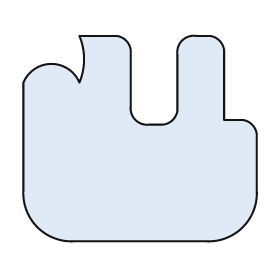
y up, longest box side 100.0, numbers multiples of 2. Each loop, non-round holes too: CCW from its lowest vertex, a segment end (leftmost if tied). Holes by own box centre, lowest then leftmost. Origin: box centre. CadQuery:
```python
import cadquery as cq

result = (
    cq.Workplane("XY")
    .moveTo(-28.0, -44.0)
    .lineTo(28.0, -44.0)
    .threePointArc((44.0, -38.0), (50.0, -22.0))
    .lineTo(50.0, 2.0)
    .threePointArc((48.0, 6.0), (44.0, 8.0))
    .lineTo(36.0, 8.0)
    .lineTo(36.0, 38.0)
    .threePointArc((34.0, 42.0), (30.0, 44.0))
    .lineTo(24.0, 44.0)
    .threePointArc((18.0, 42.0), (16.0, 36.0))
    .lineTo(16.0, 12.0)
    .threePointArc((14.0, 8.0), (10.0, 6.0))
    .lineTo(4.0, 6.0)
    .threePointArc((-2.0, 8.0), (-4.0, 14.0))
    .lineTo(-4.0, 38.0)
    .threePointArc((-6.0, 42.0), (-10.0, 44.0))
    .lineTo(-26.0, 44.0)
    .threePointArc((-24.0, 34.0), (-26.0, 24.0))
    .threePointArc((-38.0, 32.0), (-50.0, 24.0))
    .lineTo(-50.0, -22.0)
    .threePointArc((-44.0, -38.0), (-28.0, -44.0))
    .close()
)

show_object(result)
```